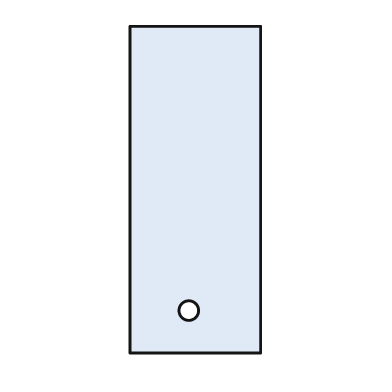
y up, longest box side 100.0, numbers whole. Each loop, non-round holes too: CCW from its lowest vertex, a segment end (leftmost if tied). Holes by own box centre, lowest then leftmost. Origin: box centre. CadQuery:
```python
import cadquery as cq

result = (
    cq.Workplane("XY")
    .moveTo(-20.0, -50.0)
    .lineTo(20.0, -50.0)
    .lineTo(20.0, 50.0)
    .lineTo(-20.0, 50.0)
    .close()
    .moveTo(-2.0, -37.0)
    .circle(3.0)
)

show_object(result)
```